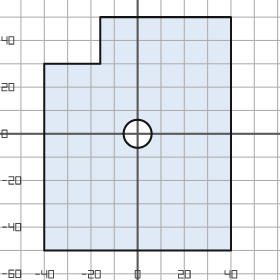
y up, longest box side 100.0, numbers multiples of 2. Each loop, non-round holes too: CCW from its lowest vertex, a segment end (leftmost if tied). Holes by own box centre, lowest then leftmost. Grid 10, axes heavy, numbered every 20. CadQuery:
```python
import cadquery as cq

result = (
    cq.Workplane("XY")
    .moveTo(-40.0, -50.0)
    .lineTo(40.0, -50.0)
    .lineTo(40.0, 50.0)
    .lineTo(-16.0, 50.0)
    .lineTo(-16.0, 30.0)
    .lineTo(-40.0, 30.0)
    .close()
    .moveTo(0.0, 0.0)
    .circle(6.0)
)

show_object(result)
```